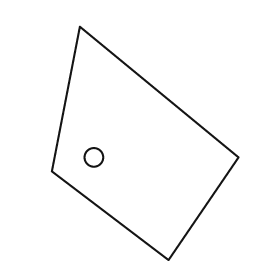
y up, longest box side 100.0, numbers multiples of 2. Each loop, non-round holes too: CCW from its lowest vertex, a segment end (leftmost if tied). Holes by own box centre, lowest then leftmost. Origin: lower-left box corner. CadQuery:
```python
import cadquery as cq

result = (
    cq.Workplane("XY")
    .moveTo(50.0, 0.0)
    .lineTo(80.0, 44.0)
    .lineTo(12.0, 100.0)
    .lineTo(0.0, 38.0)
    .close()
    .moveTo(18.0, 44.0)
    .circle(4.0)
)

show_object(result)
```